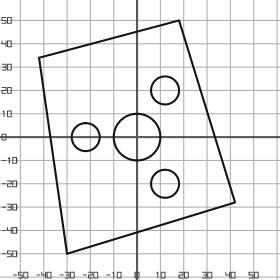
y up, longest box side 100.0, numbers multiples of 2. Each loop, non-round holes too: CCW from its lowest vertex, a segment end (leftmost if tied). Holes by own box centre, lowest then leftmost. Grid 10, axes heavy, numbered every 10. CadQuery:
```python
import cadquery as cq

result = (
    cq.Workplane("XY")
    .moveTo(-30.0, -50.0)
    .lineTo(42.0, -28.0)
    .lineTo(18.0, 50.0)
    .lineTo(-42.0, 34.0)
    .close()
    .moveTo(12.0, -20.0)
    .circle(6.0)
    .moveTo(-22.0, 0.0)
    .circle(6.0)
    .moveTo(0.0, 0.0)
    .circle(10.0)
    .moveTo(12.0, 20.0)
    .circle(6.0)
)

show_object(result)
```